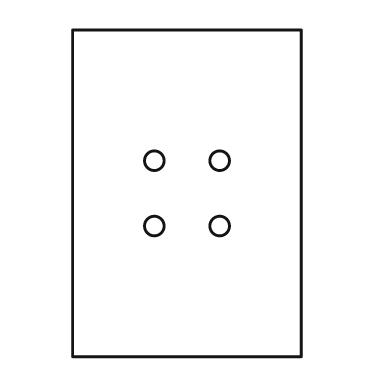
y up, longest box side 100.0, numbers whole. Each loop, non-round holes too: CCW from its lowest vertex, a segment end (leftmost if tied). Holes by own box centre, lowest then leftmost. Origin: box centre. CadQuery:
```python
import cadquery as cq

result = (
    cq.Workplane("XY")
    .moveTo(-35.0, -50.0)
    .lineTo(35.0, -50.0)
    .lineTo(35.0, 50.0)
    .lineTo(-35.0, 50.0)
    .close()
    .moveTo(-10.0, -10.0)
    .circle(3.0)
    .moveTo(10.0, -10.0)
    .circle(3.0)
    .moveTo(-10.0, 10.0)
    .circle(3.0)
    .moveTo(10.0, 10.0)
    .circle(3.0)
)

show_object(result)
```